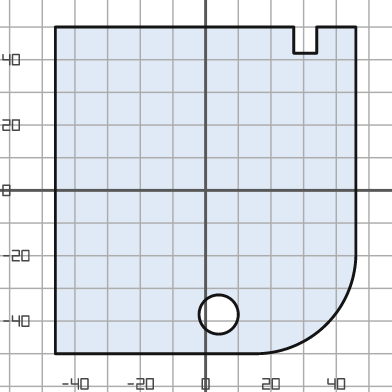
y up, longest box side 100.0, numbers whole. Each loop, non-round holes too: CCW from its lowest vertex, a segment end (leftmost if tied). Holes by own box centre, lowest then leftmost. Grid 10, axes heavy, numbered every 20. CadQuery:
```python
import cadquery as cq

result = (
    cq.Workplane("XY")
    .moveTo(-46.0, -50.0)
    .lineTo(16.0, -50.0)
    .threePointArc((37.0, -41.0), (46.0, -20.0))
    .lineTo(46.0, 50.0)
    .lineTo(34.0, 50.0)
    .lineTo(34.0, 42.0)
    .lineTo(27.0, 42.0)
    .lineTo(27.0, 50.0)
    .lineTo(-46.0, 50.0)
    .close()
    .moveTo(4.0, -38.0)
    .circle(6.0)
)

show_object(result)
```